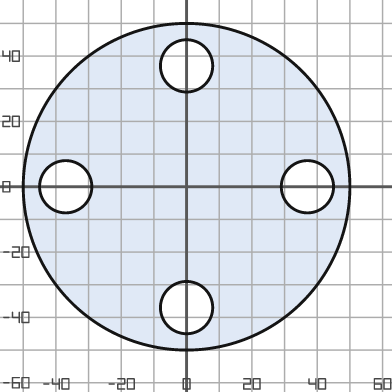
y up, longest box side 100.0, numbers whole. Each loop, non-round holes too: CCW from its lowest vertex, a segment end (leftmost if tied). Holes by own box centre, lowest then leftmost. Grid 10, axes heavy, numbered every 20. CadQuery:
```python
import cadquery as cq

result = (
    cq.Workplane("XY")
    .moveTo(0.0, 0.0)
    .circle(50.0)
    .moveTo(0.0, -37.0)
    .circle(8.0)
    .moveTo(-37.0, 0.0)
    .circle(8.0)
    .moveTo(37.0, 0.0)
    .circle(8.0)
    .moveTo(0.0, 37.0)
    .circle(8.0)
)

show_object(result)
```